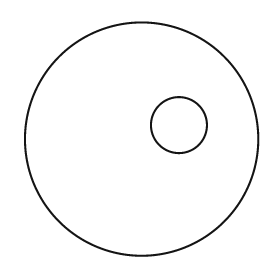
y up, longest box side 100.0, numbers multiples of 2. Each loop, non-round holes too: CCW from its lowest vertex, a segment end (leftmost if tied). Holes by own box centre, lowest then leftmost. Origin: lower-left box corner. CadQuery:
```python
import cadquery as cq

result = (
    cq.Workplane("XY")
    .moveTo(50.0, 50.0)
    .circle(50.0)
    .moveTo(66.0, 56.0)
    .circle(12.0)
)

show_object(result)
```